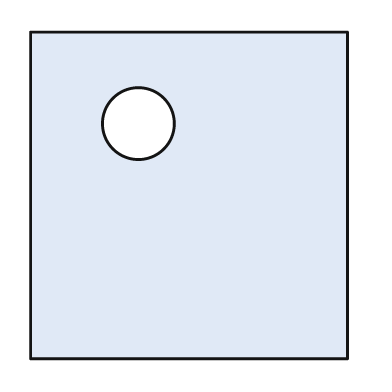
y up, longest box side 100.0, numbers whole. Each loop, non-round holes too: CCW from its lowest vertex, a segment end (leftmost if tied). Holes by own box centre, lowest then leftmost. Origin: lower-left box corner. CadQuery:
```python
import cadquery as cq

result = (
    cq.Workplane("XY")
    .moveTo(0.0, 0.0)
    .lineTo(97.0, 0.0)
    .lineTo(97.0, 100.0)
    .lineTo(0.0, 100.0)
    .close()
    .moveTo(33.0, 72.0)
    .circle(11.0)
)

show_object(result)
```